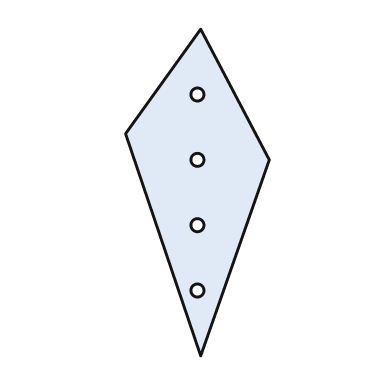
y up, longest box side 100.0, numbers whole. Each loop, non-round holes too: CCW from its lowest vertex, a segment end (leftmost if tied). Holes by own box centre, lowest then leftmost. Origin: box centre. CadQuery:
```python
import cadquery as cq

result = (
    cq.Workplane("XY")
    .moveTo(1.0, -50.0)
    .lineTo(22.0, 10.0)
    .lineTo(1.0, 50.0)
    .lineTo(-22.0, 18.0)
    .close()
    .moveTo(0.0, -30.0)
    .circle(2.0)
    .moveTo(0.0, -10.0)
    .circle(2.0)
    .moveTo(0.0, 10.0)
    .circle(2.0)
    .moveTo(0.0, 30.0)
    .circle(2.0)
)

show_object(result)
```